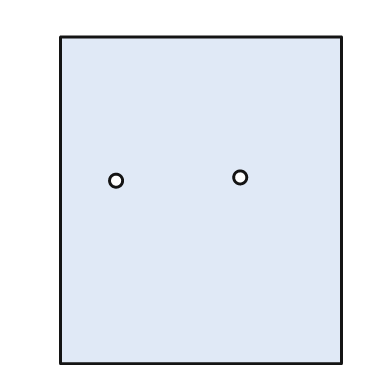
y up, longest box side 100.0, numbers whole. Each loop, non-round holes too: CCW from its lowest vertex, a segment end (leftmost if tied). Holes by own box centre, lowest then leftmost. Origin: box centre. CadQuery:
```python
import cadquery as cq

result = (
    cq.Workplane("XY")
    .moveTo(-43.0, -50.0)
    .lineTo(43.0, -50.0)
    .lineTo(43.0, 50.0)
    .lineTo(-43.0, 50.0)
    .close()
    .moveTo(-26.0, 6.0)
    .circle(2.0)
    .moveTo(12.0, 7.0)
    .circle(2.0)
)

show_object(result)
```